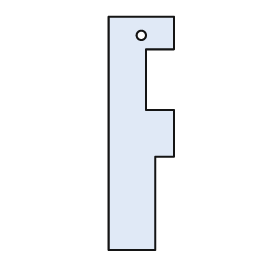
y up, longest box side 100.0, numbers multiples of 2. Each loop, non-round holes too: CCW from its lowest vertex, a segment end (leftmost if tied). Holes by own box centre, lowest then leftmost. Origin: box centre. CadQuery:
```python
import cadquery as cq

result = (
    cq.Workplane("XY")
    .moveTo(-14.0, -50.0)
    .lineTo(6.0, -50.0)
    .lineTo(6.0, -10.0)
    .lineTo(14.0, -10.0)
    .lineTo(14.0, 10.0)
    .lineTo(2.0, 10.0)
    .lineTo(2.0, 36.0)
    .lineTo(14.0, 36.0)
    .lineTo(14.0, 50.0)
    .lineTo(-14.0, 50.0)
    .close()
    .moveTo(0.0, 42.0)
    .circle(2.0)
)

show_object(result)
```